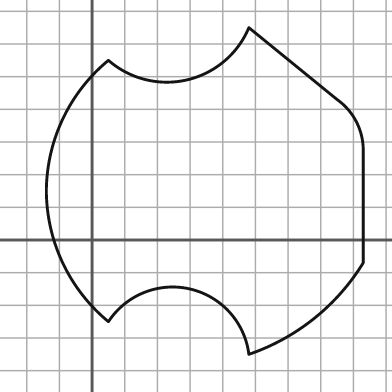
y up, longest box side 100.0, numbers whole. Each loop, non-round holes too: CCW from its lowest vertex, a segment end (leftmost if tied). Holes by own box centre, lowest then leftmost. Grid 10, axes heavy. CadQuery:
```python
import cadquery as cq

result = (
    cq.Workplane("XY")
    .moveTo(48.0, -35.0)
    .threePointArc((68.0, -24.0), (83.0, -7.0))
    .lineTo(83.0, 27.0)
    .threePointArc((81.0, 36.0), (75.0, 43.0))
    .lineTo(48.0, 65.0)
    .threePointArc((29.0, 49.0), (5.0, 55.0))
    .threePointArc((-9.0, 37.0), (-14.0, 15.0))
    .threePointArc((-9.0, -7.0), (5.0, -25.0))
    .threePointArc((30.0, -15.0), (48.0, -35.0))
    .close()
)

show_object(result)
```